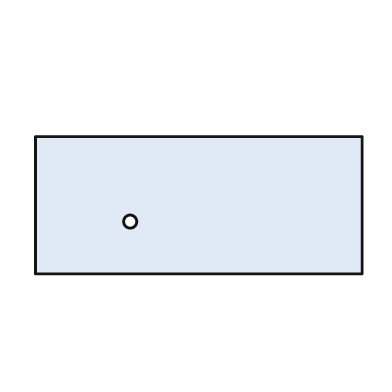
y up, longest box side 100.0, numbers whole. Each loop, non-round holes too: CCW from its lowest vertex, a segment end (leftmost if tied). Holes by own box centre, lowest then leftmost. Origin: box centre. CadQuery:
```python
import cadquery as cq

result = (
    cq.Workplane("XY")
    .moveTo(-50.0, -21.0)
    .lineTo(50.0, -21.0)
    .lineTo(50.0, 21.0)
    .lineTo(-50.0, 21.0)
    .close()
    .moveTo(-21.0, -5.0)
    .circle(2.0)
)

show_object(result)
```